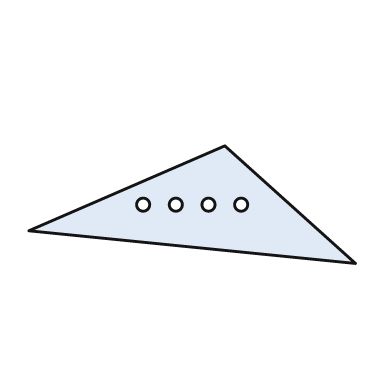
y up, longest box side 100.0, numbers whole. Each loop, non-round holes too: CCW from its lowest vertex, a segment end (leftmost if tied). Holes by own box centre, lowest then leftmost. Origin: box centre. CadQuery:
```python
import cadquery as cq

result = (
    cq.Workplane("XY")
    .moveTo(50.0, -18.0)
    .lineTo(10.0, 18.0)
    .lineTo(-50.0, -8.0)
    .close()
    .moveTo(-15.0, 0.0)
    .circle(2.0)
    .moveTo(-5.0, 0.0)
    .circle(2.0)
    .moveTo(5.0, 0.0)
    .circle(2.0)
    .moveTo(15.0, 0.0)
    .circle(2.0)
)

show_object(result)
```